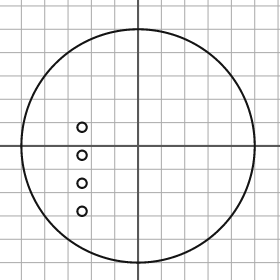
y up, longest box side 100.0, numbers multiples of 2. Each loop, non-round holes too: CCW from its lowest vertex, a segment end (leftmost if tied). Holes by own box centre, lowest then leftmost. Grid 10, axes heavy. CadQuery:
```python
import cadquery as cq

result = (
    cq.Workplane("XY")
    .moveTo(0.0, 0.0)
    .circle(50.0)
    .moveTo(-24.0, -28.0)
    .circle(2.0)
    .moveTo(-24.0, -16.0)
    .circle(2.0)
    .moveTo(-24.0, -4.0)
    .circle(2.0)
    .moveTo(-24.0, 8.0)
    .circle(2.0)
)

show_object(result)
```